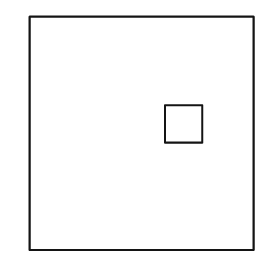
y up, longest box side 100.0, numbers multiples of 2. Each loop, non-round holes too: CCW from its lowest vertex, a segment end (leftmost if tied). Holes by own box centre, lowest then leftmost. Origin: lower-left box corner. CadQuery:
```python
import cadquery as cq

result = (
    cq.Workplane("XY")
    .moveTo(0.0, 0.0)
    .lineTo(96.0, 0.0)
    .lineTo(96.0, 100.0)
    .lineTo(0.0, 100.0)
    .close()
    .moveTo(58.0, 46.0)
    .lineTo(74.0, 46.0)
    .lineTo(74.0, 62.0)
    .lineTo(58.0, 62.0)
    .close()
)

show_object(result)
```